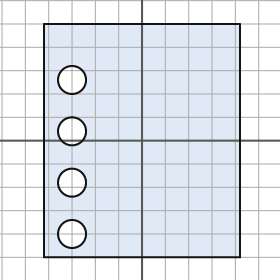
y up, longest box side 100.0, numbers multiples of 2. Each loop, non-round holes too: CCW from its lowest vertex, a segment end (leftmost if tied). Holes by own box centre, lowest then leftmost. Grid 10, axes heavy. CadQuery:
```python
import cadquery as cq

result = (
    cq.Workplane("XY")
    .moveTo(-42.0, -50.0)
    .lineTo(42.0, -50.0)
    .lineTo(42.0, 50.0)
    .lineTo(-42.0, 50.0)
    .close()
    .moveTo(-30.0, -40.0)
    .circle(6.0)
    .moveTo(-30.0, -18.0)
    .circle(6.0)
    .moveTo(-30.0, 4.0)
    .circle(6.0)
    .moveTo(-30.0, 26.0)
    .circle(6.0)
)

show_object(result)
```